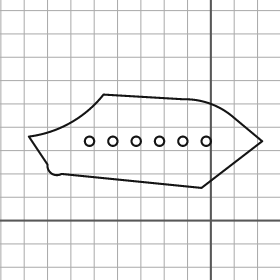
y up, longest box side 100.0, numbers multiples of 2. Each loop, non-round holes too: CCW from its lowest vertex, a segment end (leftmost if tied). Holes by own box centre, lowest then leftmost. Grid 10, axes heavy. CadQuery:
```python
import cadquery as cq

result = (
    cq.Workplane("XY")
    .moveTo(-4.0, 14.0)
    .lineTo(22.0, 34.0)
    .lineTo(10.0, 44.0)
    .threePointArc((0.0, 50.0), (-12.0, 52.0))
    .lineTo(-46.0, 54.0)
    .threePointArc((-60.0, 42.0), (-78.0, 36.0))
    .lineTo(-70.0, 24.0)
    .threePointArc((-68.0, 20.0), (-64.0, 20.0))
    .close()
    .moveTo(-52.0, 34.0)
    .circle(2.0)
    .moveTo(-42.0, 34.0)
    .circle(2.0)
    .moveTo(-32.0, 34.0)
    .circle(2.0)
    .moveTo(-22.0, 34.0)
    .circle(2.0)
    .moveTo(-12.0, 34.0)
    .circle(2.0)
    .moveTo(-2.0, 34.0)
    .circle(2.0)
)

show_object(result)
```